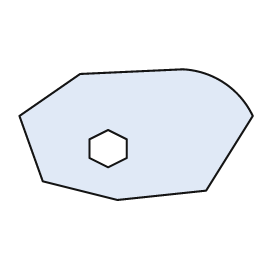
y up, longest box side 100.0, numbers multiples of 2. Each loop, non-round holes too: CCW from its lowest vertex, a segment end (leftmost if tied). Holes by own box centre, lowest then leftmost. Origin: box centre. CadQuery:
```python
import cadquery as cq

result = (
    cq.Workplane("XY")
    .moveTo(-8.0, -28.0)
    .lineTo(30.0, -24.0)
    .lineTo(50.0, 8.0)
    .threePointArc((38.0, 22.0), (20.0, 28.0))
    .lineTo(-24.0, 26.0)
    .lineTo(-50.0, 8.0)
    .lineTo(-40.0, -20.0)
    .close()
    .moveTo(-12.0, -14.0)
    .lineTo(-4.0, -10.0)
    .lineTo(-4.0, -2.0)
    .lineTo(-12.0, 2.0)
    .lineTo(-20.0, -2.0)
    .lineTo(-20.0, -10.0)
    .close()
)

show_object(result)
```